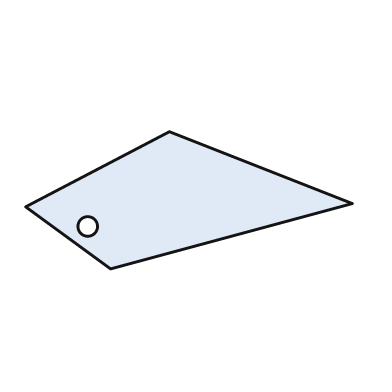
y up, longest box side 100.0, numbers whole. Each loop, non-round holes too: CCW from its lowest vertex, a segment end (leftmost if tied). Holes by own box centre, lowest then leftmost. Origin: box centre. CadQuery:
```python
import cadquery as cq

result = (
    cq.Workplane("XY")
    .moveTo(-24.0, -21.0)
    .lineTo(50.0, -1.0)
    .lineTo(-6.0, 21.0)
    .lineTo(-50.0, -2.0)
    .close()
    .moveTo(-31.0, -8.0)
    .circle(3.0)
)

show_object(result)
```